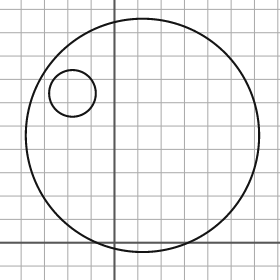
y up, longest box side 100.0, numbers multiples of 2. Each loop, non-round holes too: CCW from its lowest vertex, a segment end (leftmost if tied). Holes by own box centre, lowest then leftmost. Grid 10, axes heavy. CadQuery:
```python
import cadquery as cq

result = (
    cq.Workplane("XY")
    .moveTo(12.0, 46.0)
    .circle(50.0)
    .moveTo(-18.0, 64.0)
    .circle(10.0)
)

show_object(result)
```